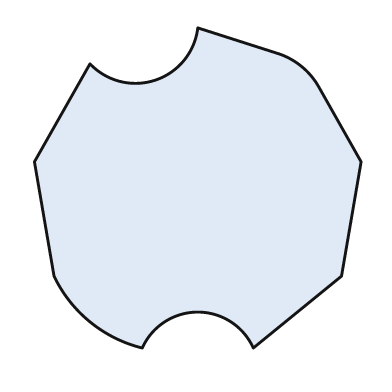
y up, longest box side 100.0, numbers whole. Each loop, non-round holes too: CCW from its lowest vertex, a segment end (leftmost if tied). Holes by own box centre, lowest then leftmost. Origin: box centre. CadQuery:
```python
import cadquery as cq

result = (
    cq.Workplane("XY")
    .moveTo(-17.0, -49.0)
    .threePointArc((0.0, -38.0), (17.0, -49.0))
    .lineTo(44.0, -27.0)
    .lineTo(50.0, 8.0)
    .lineTo(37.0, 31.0)
    .threePointArc((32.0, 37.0), (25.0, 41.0))
    .lineTo(0.0, 49.0)
    .threePointArc((-13.0, 33.0), (-33.0, 38.0))
    .lineTo(-50.0, 8.0)
    .lineTo(-44.0, -27.0)
    .threePointArc((-33.0, -41.0), (-17.0, -49.0))
    .close()
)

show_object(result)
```